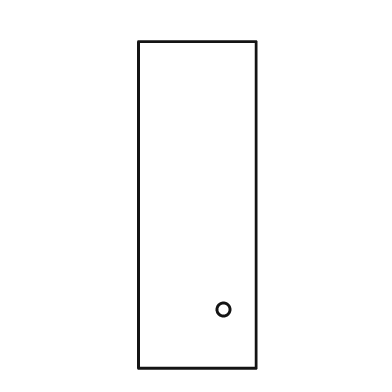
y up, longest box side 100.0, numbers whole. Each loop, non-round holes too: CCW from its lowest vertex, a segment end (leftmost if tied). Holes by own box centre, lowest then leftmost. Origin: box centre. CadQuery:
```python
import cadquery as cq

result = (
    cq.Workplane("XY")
    .moveTo(-18.0, -50.0)
    .lineTo(18.0, -50.0)
    .lineTo(18.0, 50.0)
    .lineTo(-18.0, 50.0)
    .close()
    .moveTo(8.0, -32.0)
    .circle(2.0)
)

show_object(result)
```